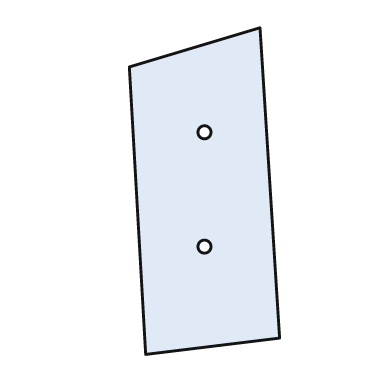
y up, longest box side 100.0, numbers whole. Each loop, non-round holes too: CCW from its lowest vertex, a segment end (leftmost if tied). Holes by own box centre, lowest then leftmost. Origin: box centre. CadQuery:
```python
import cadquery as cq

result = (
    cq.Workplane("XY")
    .moveTo(-18.0, -50.0)
    .lineTo(23.0, -45.0)
    .lineTo(17.0, 50.0)
    .lineTo(-23.0, 38.0)
    .close()
    .moveTo(0.0, -17.0)
    .circle(2.0)
    .moveTo(0.0, 18.0)
    .circle(2.0)
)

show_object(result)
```